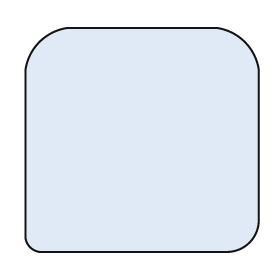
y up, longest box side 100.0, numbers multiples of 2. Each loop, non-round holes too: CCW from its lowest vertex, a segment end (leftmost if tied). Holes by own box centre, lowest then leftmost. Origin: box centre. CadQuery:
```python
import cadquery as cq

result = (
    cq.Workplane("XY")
    .moveTo(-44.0, -48.0)
    .lineTo(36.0, -48.0)
    .threePointArc((46.0, -44.0), (50.0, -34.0))
    .lineTo(50.0, 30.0)
    .threePointArc((44.0, 42.0), (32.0, 48.0))
    .lineTo(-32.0, 48.0)
    .threePointArc((-44.0, 42.0), (-50.0, 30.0))
    .lineTo(-50.0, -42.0)
    .threePointArc((-48.0, -46.0), (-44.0, -48.0))
    .close()
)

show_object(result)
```